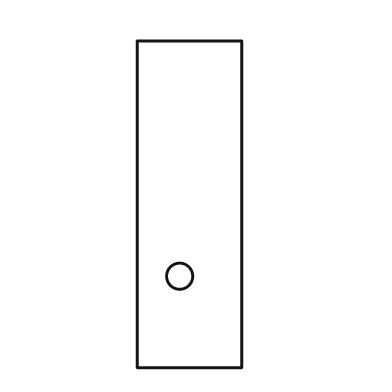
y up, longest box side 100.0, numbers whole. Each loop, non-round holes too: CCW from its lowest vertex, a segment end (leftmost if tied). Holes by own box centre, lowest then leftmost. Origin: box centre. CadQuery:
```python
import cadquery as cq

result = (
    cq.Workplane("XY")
    .moveTo(-16.0, -50.0)
    .lineTo(16.0, -50.0)
    .lineTo(16.0, 50.0)
    .lineTo(-16.0, 50.0)
    .close()
    .moveTo(-3.0, -22.0)
    .circle(4.0)
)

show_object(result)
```